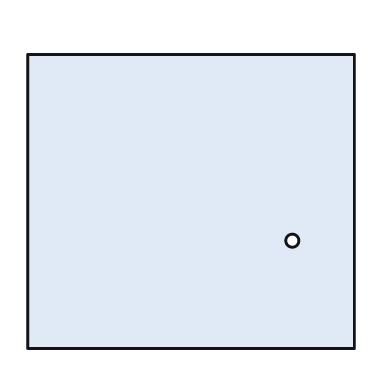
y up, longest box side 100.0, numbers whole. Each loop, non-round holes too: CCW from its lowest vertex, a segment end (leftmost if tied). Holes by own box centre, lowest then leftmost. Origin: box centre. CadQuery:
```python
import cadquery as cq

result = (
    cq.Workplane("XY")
    .moveTo(-50.0, -45.0)
    .lineTo(50.0, -45.0)
    .lineTo(50.0, 45.0)
    .lineTo(-50.0, 45.0)
    .close()
    .moveTo(31.0, -12.0)
    .circle(2.0)
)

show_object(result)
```